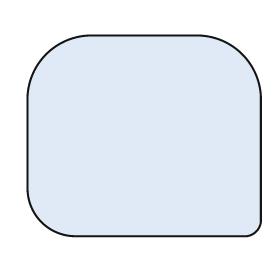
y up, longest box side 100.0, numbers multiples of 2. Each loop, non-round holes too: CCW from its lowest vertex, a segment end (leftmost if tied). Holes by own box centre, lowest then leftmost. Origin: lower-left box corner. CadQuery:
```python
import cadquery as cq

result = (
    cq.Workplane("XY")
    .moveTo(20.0, 0.0)
    .lineTo(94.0, 0.0)
    .threePointArc((98.0, 2.0), (100.0, 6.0))
    .lineTo(100.0, 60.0)
    .threePointArc((92.0, 78.0), (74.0, 86.0))
    .lineTo(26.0, 86.0)
    .threePointArc((8.0, 78.0), (0.0, 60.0))
    .lineTo(0.0, 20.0)
    .threePointArc((6.0, 6.0), (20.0, 0.0))
    .close()
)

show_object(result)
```